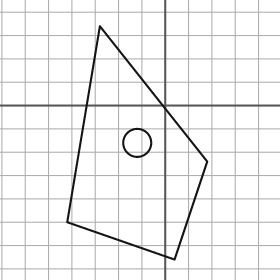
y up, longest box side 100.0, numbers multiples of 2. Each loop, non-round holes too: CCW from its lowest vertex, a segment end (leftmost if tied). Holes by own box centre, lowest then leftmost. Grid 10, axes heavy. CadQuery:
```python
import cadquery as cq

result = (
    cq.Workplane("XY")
    .moveTo(4.0, -66.0)
    .lineTo(18.0, -24.0)
    .lineTo(-28.0, 34.0)
    .lineTo(-42.0, -50.0)
    .close()
    .moveTo(-12.0, -16.0)
    .circle(6.0)
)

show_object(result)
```